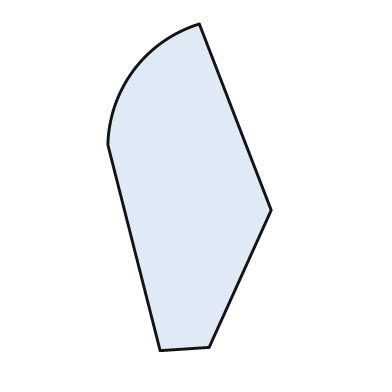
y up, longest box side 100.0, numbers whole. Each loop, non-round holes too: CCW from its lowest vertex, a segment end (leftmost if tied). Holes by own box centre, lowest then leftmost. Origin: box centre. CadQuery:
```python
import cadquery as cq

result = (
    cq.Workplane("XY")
    .moveTo(-9.0, -50.0)
    .lineTo(6.0, -49.0)
    .lineTo(25.0, -7.0)
    .lineTo(3.0, 50.0)
    .threePointArc((-17.0, 36.0), (-25.0, 13.0))
    .close()
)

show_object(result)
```